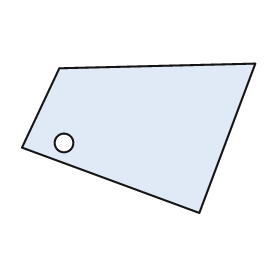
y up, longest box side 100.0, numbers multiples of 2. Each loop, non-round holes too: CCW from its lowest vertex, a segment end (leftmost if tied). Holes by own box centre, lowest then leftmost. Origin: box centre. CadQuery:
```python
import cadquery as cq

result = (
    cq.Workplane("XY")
    .moveTo(26.0, -32.0)
    .lineTo(50.0, 32.0)
    .lineTo(-34.0, 30.0)
    .lineTo(-50.0, -4.0)
    .close()
    .moveTo(-32.0, -2.0)
    .circle(4.0)
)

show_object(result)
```